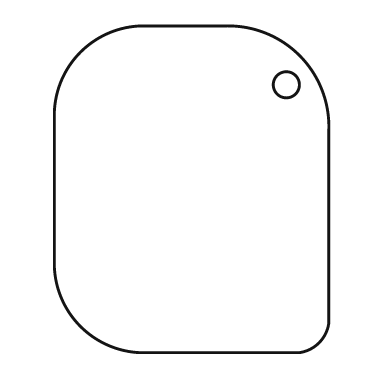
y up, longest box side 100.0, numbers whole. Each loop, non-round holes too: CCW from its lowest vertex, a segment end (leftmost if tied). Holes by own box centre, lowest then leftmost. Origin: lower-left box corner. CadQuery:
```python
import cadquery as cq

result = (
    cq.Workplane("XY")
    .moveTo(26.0, 0.0)
    .lineTo(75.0, 0.0)
    .threePointArc((81.0, 3.0), (84.0, 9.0))
    .lineTo(84.0, 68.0)
    .threePointArc((75.0, 91.0), (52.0, 100.0))
    .lineTo(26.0, 100.0)
    .threePointArc((8.0, 92.0), (0.0, 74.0))
    .lineTo(0.0, 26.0)
    .threePointArc((8.0, 8.0), (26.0, 0.0))
    .close()
    .moveTo(71.0, 82.0)
    .circle(4.0)
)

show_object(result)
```